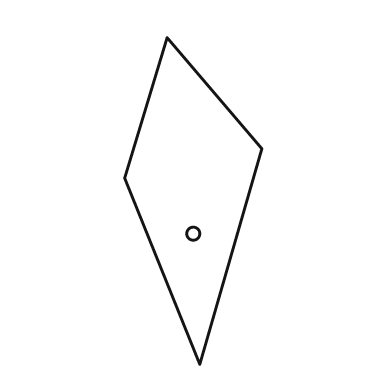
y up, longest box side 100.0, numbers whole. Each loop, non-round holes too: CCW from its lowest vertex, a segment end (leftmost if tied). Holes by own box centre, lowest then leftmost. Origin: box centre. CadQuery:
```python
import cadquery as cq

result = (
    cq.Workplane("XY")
    .moveTo(2.0, -50.0)
    .lineTo(21.0, 16.0)
    .lineTo(-8.0, 50.0)
    .lineTo(-21.0, 7.0)
    .close()
    .moveTo(0.0, -10.0)
    .circle(2.0)
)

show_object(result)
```